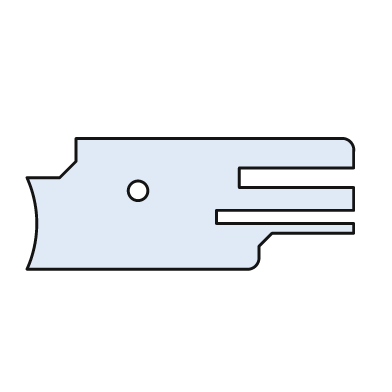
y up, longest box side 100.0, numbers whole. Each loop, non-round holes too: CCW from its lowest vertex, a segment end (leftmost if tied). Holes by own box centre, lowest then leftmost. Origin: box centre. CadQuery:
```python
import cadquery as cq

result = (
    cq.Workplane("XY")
    .moveTo(-50.0, -20.0)
    .lineTo(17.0, -20.0)
    .threePointArc((20.0, -19.0), (21.0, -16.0))
    .lineTo(21.0, -13.0)
    .lineTo(25.0, -9.0)
    .lineTo(50.0, -9.0)
    .lineTo(50.0, -6.0)
    .lineTo(8.0, -6.0)
    .lineTo(8.0, -2.0)
    .lineTo(50.0, -2.0)
    .lineTo(50.0, 5.0)
    .lineTo(15.0, 5.0)
    .lineTo(15.0, 11.0)
    .lineTo(50.0, 11.0)
    .lineTo(50.0, 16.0)
    .threePointArc((49.0, 19.0), (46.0, 20.0))
    .lineTo(-35.0, 20.0)
    .lineTo(-35.0, 13.0)
    .lineTo(-40.0, 8.0)
    .lineTo(-50.0, 8.0)
    .threePointArc((-47.0, -6.0), (-50.0, -20.0))
    .close()
    .moveTo(-16.0, 4.0)
    .circle(3.0)
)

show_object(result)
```